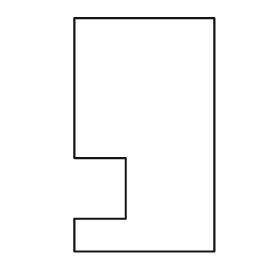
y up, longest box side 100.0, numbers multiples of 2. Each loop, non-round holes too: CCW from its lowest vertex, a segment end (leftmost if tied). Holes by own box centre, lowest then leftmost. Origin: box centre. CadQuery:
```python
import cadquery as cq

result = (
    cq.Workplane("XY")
    .moveTo(-30.0, -50.0)
    .lineTo(30.0, -50.0)
    .lineTo(30.0, 50.0)
    .lineTo(-30.0, 50.0)
    .lineTo(-30.0, -10.0)
    .lineTo(-8.0, -10.0)
    .lineTo(-8.0, -36.0)
    .lineTo(-30.0, -36.0)
    .close()
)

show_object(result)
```